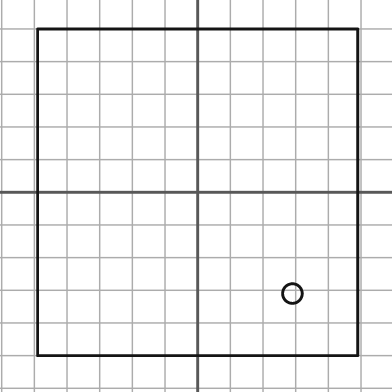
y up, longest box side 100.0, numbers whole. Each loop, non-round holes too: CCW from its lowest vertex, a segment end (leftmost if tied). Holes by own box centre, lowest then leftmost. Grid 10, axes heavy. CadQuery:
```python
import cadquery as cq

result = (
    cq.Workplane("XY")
    .moveTo(-49.0, -50.0)
    .lineTo(49.0, -50.0)
    .lineTo(49.0, 50.0)
    .lineTo(-49.0, 50.0)
    .close()
    .moveTo(29.0, -31.0)
    .circle(3.0)
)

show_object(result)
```